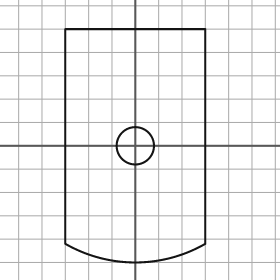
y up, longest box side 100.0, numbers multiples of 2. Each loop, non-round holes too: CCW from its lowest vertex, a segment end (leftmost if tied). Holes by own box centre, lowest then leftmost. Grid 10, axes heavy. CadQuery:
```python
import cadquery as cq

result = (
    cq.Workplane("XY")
    .moveTo(-30.0, -42.0)
    .threePointArc((0.0, -50.0), (30.0, -42.0))
    .lineTo(30.0, 50.0)
    .lineTo(-30.0, 50.0)
    .close()
    .moveTo(0.0, 0.0)
    .circle(8.0)
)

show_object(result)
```